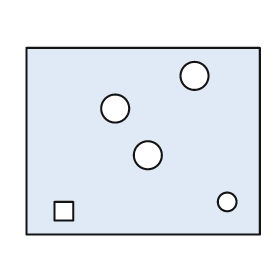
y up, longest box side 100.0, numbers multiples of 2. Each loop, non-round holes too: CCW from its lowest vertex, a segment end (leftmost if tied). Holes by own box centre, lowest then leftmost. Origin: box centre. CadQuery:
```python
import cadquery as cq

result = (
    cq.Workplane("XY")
    .moveTo(-50.0, -40.0)
    .lineTo(50.0, -40.0)
    .lineTo(50.0, 40.0)
    .lineTo(-50.0, 40.0)
    .close()
    .moveTo(-38.0, -34.0)
    .lineTo(-30.0, -34.0)
    .lineTo(-30.0, -26.0)
    .lineTo(-38.0, -26.0)
    .close()
    .moveTo(36.0, -26.0)
    .circle(4.0)
    .moveTo(2.0, -6.0)
    .circle(6.0)
    .moveTo(-12.0, 14.0)
    .circle(6.0)
    .moveTo(22.0, 28.0)
    .circle(6.0)
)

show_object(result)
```